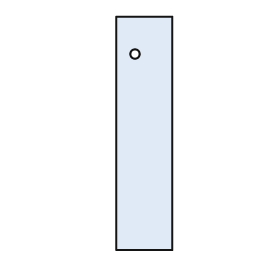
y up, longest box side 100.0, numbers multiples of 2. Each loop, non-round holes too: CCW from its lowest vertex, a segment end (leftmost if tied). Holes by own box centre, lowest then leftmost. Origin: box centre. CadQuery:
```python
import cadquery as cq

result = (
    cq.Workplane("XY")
    .moveTo(-12.0, -50.0)
    .lineTo(12.0, -50.0)
    .lineTo(12.0, 50.0)
    .lineTo(-12.0, 50.0)
    .close()
    .moveTo(-4.0, 34.0)
    .circle(2.0)
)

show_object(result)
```